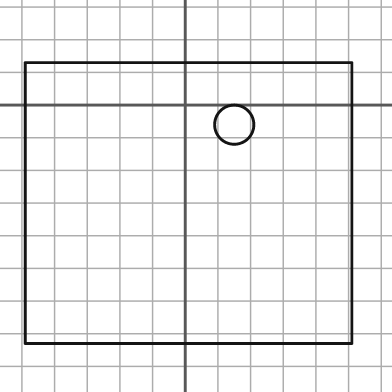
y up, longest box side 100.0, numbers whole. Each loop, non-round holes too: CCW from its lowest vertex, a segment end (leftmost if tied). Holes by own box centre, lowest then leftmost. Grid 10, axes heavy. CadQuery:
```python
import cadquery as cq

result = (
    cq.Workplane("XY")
    .moveTo(-49.0, -73.0)
    .lineTo(51.0, -73.0)
    .lineTo(51.0, 13.0)
    .lineTo(-49.0, 13.0)
    .close()
    .moveTo(15.0, -6.0)
    .circle(6.0)
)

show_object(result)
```